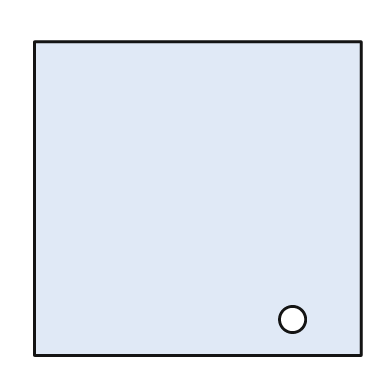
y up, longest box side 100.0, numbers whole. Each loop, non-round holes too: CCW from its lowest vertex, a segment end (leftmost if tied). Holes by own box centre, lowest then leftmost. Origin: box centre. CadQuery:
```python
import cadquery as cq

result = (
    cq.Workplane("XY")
    .moveTo(-50.0, -48.0)
    .lineTo(50.0, -48.0)
    .lineTo(50.0, 48.0)
    .lineTo(-50.0, 48.0)
    .close()
    .moveTo(29.0, -37.0)
    .circle(4.0)
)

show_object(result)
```